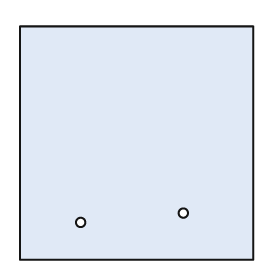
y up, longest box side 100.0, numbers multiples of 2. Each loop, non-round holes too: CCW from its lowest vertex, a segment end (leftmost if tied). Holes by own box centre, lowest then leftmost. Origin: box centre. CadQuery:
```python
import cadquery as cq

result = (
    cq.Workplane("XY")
    .moveTo(-50.0, -50.0)
    .lineTo(50.0, -50.0)
    .lineTo(50.0, 50.0)
    .lineTo(-50.0, 50.0)
    .close()
    .moveTo(-24.0, -34.0)
    .circle(2.0)
    .moveTo(20.0, -30.0)
    .circle(2.0)
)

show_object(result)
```